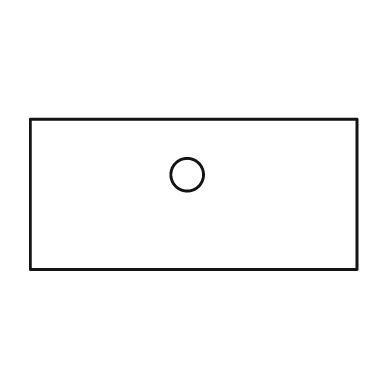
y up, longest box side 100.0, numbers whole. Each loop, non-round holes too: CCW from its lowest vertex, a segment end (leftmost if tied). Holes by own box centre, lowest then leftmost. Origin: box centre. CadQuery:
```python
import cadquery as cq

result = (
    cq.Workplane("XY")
    .moveTo(-50.0, -23.0)
    .lineTo(50.0, -23.0)
    .lineTo(50.0, 23.0)
    .lineTo(-50.0, 23.0)
    .close()
    .moveTo(-2.0, 6.0)
    .circle(5.0)
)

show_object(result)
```